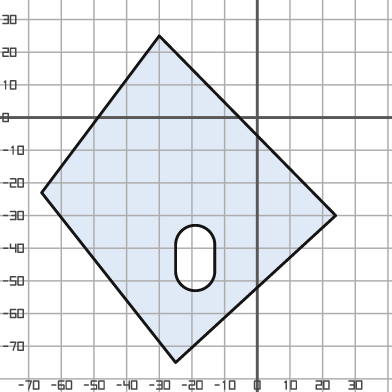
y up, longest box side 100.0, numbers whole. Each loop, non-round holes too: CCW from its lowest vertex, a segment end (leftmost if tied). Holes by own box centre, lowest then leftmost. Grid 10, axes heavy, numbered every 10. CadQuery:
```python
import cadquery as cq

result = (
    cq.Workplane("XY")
    .moveTo(-25.0, -75.0)
    .lineTo(24.0, -30.0)
    .lineTo(-30.0, 25.0)
    .lineTo(-66.0, -23.0)
    .close()
    .moveTo(-25.0, -47.0)
    .threePointArc((-19.0, -53.0), (-13.0, -47.0))
    .lineTo(-13.0, -39.0)
    .threePointArc((-19.0, -33.0), (-25.0, -39.0))
    .close()
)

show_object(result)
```